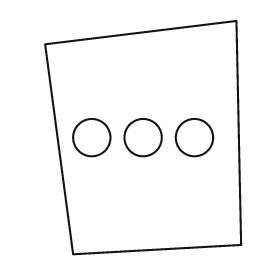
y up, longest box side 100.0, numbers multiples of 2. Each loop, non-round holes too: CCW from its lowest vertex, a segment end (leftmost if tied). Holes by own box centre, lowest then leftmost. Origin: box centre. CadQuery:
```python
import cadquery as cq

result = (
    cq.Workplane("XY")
    .moveTo(-30.0, -50.0)
    .lineTo(42.0, -46.0)
    .lineTo(40.0, 50.0)
    .lineTo(-42.0, 40.0)
    .close()
    .moveTo(-22.0, 0.0)
    .circle(8.0)
    .moveTo(0.0, 0.0)
    .circle(8.0)
    .moveTo(22.0, 0.0)
    .circle(8.0)
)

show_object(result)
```